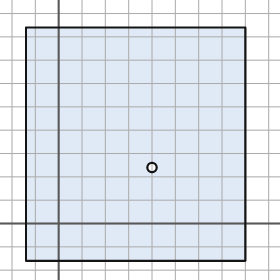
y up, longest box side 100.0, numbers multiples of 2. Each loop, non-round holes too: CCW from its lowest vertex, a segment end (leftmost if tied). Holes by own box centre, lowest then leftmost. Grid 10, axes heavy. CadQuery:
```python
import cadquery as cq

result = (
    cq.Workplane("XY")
    .moveTo(-14.0, -16.0)
    .lineTo(80.0, -16.0)
    .lineTo(80.0, 84.0)
    .lineTo(-14.0, 84.0)
    .close()
    .moveTo(40.0, 24.0)
    .circle(2.0)
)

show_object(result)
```